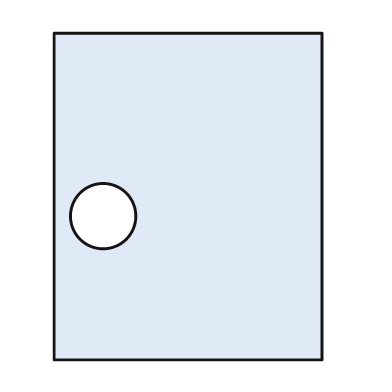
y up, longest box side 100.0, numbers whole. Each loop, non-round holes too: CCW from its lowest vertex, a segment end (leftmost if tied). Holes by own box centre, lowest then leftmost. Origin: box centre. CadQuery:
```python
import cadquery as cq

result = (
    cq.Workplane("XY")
    .moveTo(-41.0, -50.0)
    .lineTo(41.0, -50.0)
    .lineTo(41.0, 50.0)
    .lineTo(-41.0, 50.0)
    .close()
    .moveTo(-26.0, -6.0)
    .circle(10.0)
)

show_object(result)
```